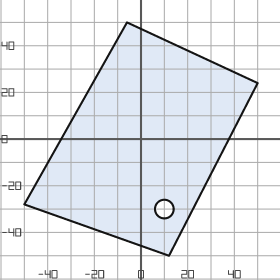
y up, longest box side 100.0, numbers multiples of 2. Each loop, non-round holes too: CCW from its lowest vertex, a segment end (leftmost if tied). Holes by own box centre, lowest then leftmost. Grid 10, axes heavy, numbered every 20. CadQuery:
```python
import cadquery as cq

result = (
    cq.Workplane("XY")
    .moveTo(12.0, -50.0)
    .lineTo(50.0, 24.0)
    .lineTo(-6.0, 50.0)
    .lineTo(-50.0, -28.0)
    .close()
    .moveTo(10.0, -30.0)
    .circle(4.0)
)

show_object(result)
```